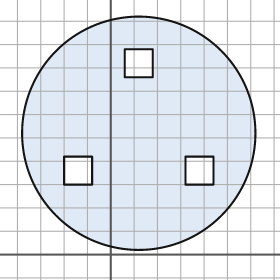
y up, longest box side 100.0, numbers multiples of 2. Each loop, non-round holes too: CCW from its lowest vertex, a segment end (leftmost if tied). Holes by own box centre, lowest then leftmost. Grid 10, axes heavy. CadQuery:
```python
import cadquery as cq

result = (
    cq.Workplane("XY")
    .moveTo(12.0, 52.0)
    .circle(50.0)
    .moveTo(-20.0, 30.0)
    .lineTo(-8.0, 30.0)
    .lineTo(-8.0, 42.0)
    .lineTo(-20.0, 42.0)
    .close()
    .moveTo(32.0, 30.0)
    .lineTo(44.0, 30.0)
    .lineTo(44.0, 42.0)
    .lineTo(32.0, 42.0)
    .close()
    .moveTo(6.0, 76.0)
    .lineTo(18.0, 76.0)
    .lineTo(18.0, 88.0)
    .lineTo(6.0, 88.0)
    .close()
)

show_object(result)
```